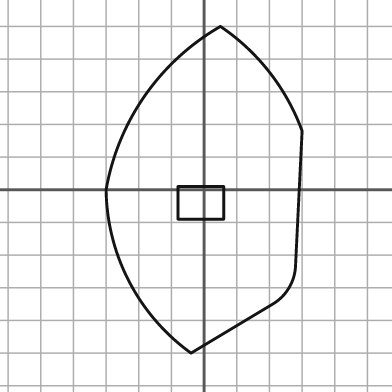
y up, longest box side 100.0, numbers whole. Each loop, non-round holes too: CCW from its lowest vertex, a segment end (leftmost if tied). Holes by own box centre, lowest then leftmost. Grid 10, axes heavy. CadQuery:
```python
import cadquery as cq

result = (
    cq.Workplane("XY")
    .moveTo(-4.0, -50.0)
    .lineTo(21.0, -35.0)
    .threePointArc((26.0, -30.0), (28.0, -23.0))
    .lineTo(30.0, 18.0)
    .threePointArc((20.0, 36.0), (5.0, 50.0))
    .threePointArc((-18.0, 29.0), (-30.0, 0.0))
    .threePointArc((-23.0, -28.0), (-4.0, -50.0))
    .close()
    .moveTo(-8.0, -9.0)
    .lineTo(6.0, -9.0)
    .lineTo(6.0, 1.0)
    .lineTo(-8.0, 1.0)
    .close()
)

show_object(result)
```